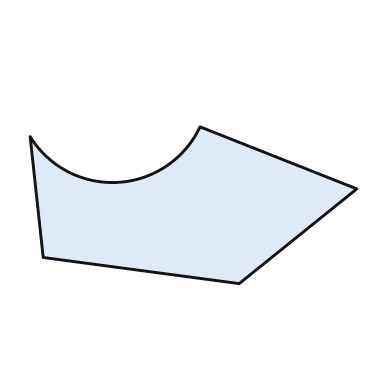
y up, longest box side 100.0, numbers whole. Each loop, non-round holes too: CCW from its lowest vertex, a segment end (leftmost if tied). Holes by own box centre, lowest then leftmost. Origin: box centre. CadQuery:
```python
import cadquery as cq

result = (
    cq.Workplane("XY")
    .moveTo(14.0, -24.0)
    .lineTo(50.0, 5.0)
    .lineTo(2.0, 24.0)
    .threePointArc((-23.0, 7.0), (-50.0, 21.0))
    .lineTo(-46.0, -16.0)
    .close()
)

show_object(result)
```